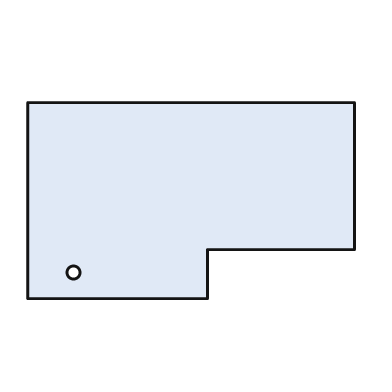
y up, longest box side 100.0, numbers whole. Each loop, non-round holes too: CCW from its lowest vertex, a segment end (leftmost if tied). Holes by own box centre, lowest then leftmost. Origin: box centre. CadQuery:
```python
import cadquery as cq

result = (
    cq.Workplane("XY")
    .moveTo(-50.0, -30.0)
    .lineTo(5.0, -30.0)
    .lineTo(5.0, -15.0)
    .lineTo(50.0, -15.0)
    .lineTo(50.0, 30.0)
    .lineTo(-50.0, 30.0)
    .close()
    .moveTo(-36.0, -22.0)
    .circle(2.0)
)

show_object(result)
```